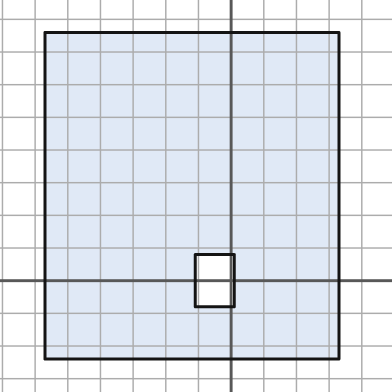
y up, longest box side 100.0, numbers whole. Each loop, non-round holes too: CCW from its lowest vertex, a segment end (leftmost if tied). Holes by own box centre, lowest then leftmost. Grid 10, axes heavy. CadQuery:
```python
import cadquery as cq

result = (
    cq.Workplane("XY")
    .moveTo(-57.0, -24.0)
    .lineTo(33.0, -24.0)
    .lineTo(33.0, 76.0)
    .lineTo(-57.0, 76.0)
    .close()
    .moveTo(-11.0, -8.0)
    .lineTo(1.0, -8.0)
    .lineTo(1.0, 8.0)
    .lineTo(-11.0, 8.0)
    .close()
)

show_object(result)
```